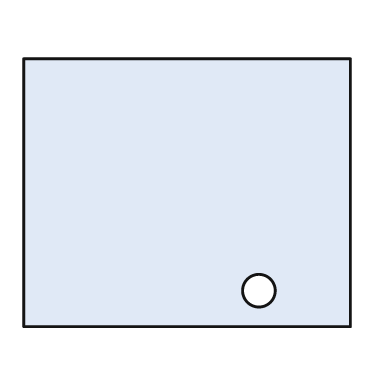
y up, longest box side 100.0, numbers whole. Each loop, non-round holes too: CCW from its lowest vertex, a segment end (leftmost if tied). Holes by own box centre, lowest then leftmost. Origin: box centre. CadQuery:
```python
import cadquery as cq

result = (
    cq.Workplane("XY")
    .moveTo(-50.0, -41.0)
    .lineTo(50.0, -41.0)
    .lineTo(50.0, 41.0)
    .lineTo(-50.0, 41.0)
    .close()
    .moveTo(22.0, -30.0)
    .circle(5.0)
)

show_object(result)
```